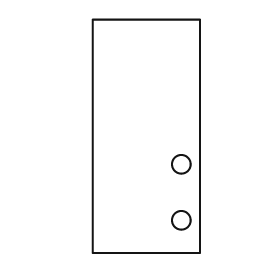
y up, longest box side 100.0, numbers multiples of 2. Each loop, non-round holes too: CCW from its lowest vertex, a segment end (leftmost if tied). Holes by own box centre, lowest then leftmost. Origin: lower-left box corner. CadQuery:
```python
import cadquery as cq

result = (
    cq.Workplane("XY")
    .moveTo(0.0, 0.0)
    .lineTo(46.0, 0.0)
    .lineTo(46.0, 100.0)
    .lineTo(0.0, 100.0)
    .close()
    .moveTo(38.0, 14.0)
    .circle(4.0)
    .moveTo(38.0, 38.0)
    .circle(4.0)
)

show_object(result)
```